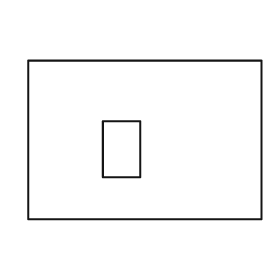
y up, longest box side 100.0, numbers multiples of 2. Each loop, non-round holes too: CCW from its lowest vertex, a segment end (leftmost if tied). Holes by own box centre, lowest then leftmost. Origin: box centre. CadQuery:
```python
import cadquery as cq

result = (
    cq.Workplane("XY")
    .moveTo(-50.0, -34.0)
    .lineTo(50.0, -34.0)
    .lineTo(50.0, 34.0)
    .lineTo(-50.0, 34.0)
    .close()
    .moveTo(-18.0, -16.0)
    .lineTo(-2.0, -16.0)
    .lineTo(-2.0, 8.0)
    .lineTo(-18.0, 8.0)
    .close()
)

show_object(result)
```